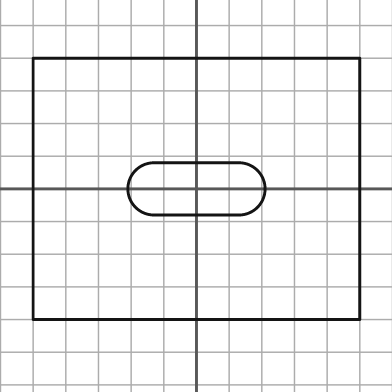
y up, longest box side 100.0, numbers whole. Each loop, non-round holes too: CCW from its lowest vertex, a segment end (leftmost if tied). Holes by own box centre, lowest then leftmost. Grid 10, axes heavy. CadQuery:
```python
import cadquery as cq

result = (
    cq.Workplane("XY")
    .moveTo(-50.0, -40.0)
    .lineTo(50.0, -40.0)
    .lineTo(50.0, 40.0)
    .lineTo(-50.0, 40.0)
    .close()
    .moveTo(-13.0, -8.0)
    .lineTo(13.0, -8.0)
    .threePointArc((21.0, 0.0), (13.0, 8.0))
    .lineTo(-13.0, 8.0)
    .threePointArc((-21.0, 0.0), (-13.0, -8.0))
    .close()
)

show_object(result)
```